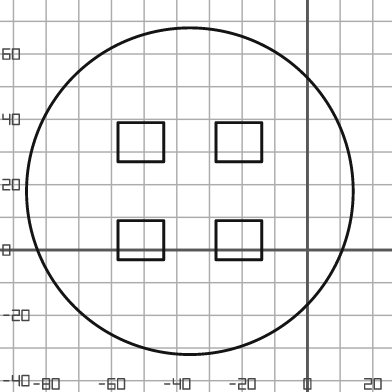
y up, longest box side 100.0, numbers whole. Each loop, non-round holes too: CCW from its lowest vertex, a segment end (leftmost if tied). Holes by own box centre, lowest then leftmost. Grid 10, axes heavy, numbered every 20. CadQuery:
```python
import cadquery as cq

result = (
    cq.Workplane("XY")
    .moveTo(-36.0, 18.0)
    .circle(50.0)
    .moveTo(-58.0, -3.0)
    .lineTo(-44.0, -3.0)
    .lineTo(-44.0, 9.0)
    .lineTo(-58.0, 9.0)
    .close()
    .moveTo(-28.0, -3.0)
    .lineTo(-14.0, -3.0)
    .lineTo(-14.0, 9.0)
    .lineTo(-28.0, 9.0)
    .close()
    .moveTo(-58.0, 27.0)
    .lineTo(-44.0, 27.0)
    .lineTo(-44.0, 39.0)
    .lineTo(-58.0, 39.0)
    .close()
    .moveTo(-28.0, 27.0)
    .lineTo(-14.0, 27.0)
    .lineTo(-14.0, 39.0)
    .lineTo(-28.0, 39.0)
    .close()
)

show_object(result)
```